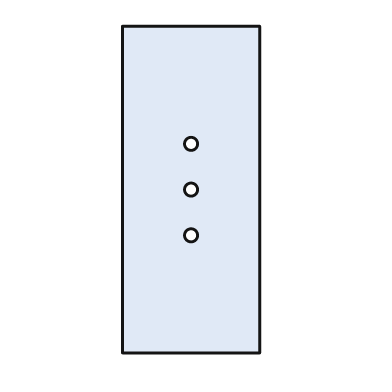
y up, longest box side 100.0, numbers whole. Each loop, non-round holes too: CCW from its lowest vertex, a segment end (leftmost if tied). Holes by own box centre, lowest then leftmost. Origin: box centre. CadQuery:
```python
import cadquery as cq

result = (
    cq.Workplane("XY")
    .moveTo(-21.0, -50.0)
    .lineTo(21.0, -50.0)
    .lineTo(21.0, 50.0)
    .lineTo(-21.0, 50.0)
    .close()
    .moveTo(0.0, -14.0)
    .circle(2.0)
    .moveTo(0.0, 0.0)
    .circle(2.0)
    .moveTo(0.0, 14.0)
    .circle(2.0)
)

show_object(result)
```